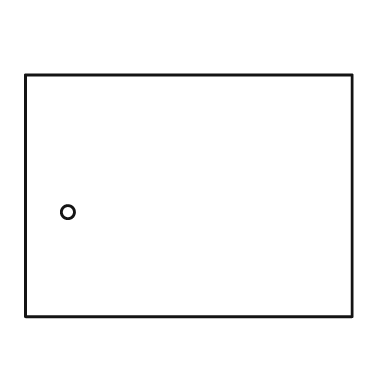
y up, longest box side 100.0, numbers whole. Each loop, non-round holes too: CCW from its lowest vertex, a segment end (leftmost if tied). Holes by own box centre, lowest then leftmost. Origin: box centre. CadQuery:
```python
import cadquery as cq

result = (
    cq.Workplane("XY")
    .moveTo(-50.0, -37.0)
    .lineTo(50.0, -37.0)
    .lineTo(50.0, 37.0)
    .lineTo(-50.0, 37.0)
    .close()
    .moveTo(-37.0, -5.0)
    .circle(2.0)
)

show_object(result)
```